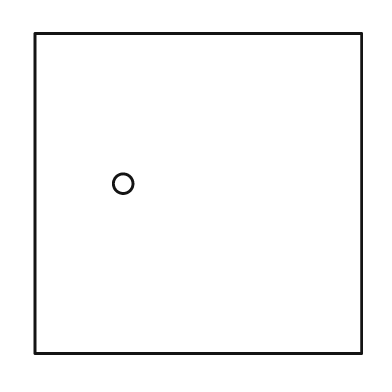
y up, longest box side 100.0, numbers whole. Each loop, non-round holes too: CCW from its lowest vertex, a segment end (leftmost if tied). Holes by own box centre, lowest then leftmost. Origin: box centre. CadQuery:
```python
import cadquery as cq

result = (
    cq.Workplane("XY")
    .moveTo(-50.0, -49.0)
    .lineTo(50.0, -49.0)
    .lineTo(50.0, 49.0)
    .lineTo(-50.0, 49.0)
    .close()
    .moveTo(-23.0, 3.0)
    .circle(3.0)
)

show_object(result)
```